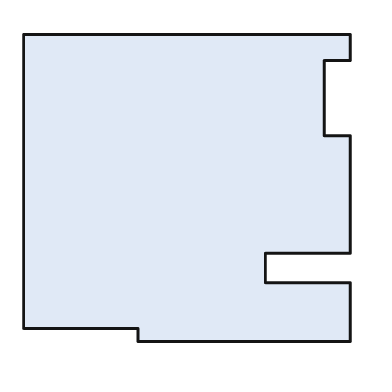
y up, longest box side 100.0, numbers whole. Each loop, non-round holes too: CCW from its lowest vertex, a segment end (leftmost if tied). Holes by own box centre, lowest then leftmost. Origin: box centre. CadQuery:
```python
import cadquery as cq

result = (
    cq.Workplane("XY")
    .moveTo(-15.0, -47.0)
    .lineTo(50.0, -47.0)
    .lineTo(50.0, -29.0)
    .lineTo(24.0, -29.0)
    .lineTo(24.0, -20.0)
    .lineTo(50.0, -20.0)
    .lineTo(50.0, 16.0)
    .lineTo(42.0, 16.0)
    .lineTo(42.0, 39.0)
    .lineTo(50.0, 39.0)
    .lineTo(50.0, 47.0)
    .lineTo(-50.0, 47.0)
    .lineTo(-50.0, -43.0)
    .lineTo(-15.0, -43.0)
    .close()
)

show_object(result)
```